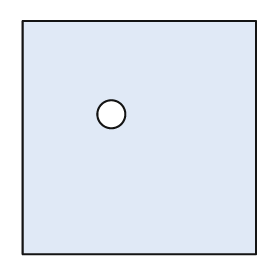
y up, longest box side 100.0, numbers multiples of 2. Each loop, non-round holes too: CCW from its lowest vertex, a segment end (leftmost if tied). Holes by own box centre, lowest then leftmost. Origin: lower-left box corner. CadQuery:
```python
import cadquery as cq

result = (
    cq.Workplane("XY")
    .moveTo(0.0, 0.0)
    .lineTo(100.0, 0.0)
    .lineTo(100.0, 100.0)
    .lineTo(0.0, 100.0)
    .close()
    .moveTo(38.0, 60.0)
    .circle(6.0)
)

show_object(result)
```